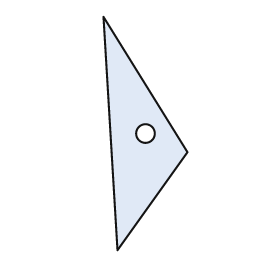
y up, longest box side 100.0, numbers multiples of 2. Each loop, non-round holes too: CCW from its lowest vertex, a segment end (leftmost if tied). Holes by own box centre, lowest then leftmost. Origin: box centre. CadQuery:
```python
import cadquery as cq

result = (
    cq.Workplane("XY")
    .moveTo(-12.0, -50.0)
    .lineTo(18.0, -8.0)
    .lineTo(-18.0, 50.0)
    .close()
    .moveTo(0.0, 0.0)
    .circle(4.0)
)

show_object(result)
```